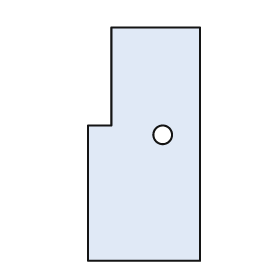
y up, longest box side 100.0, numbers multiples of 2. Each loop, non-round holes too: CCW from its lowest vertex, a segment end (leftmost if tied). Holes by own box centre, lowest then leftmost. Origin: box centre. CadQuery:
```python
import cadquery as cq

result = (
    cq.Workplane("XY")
    .moveTo(-24.0, -50.0)
    .lineTo(24.0, -50.0)
    .lineTo(24.0, 50.0)
    .lineTo(-14.0, 50.0)
    .lineTo(-14.0, 8.0)
    .lineTo(-24.0, 8.0)
    .close()
    .moveTo(8.0, 4.0)
    .circle(4.0)
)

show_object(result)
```